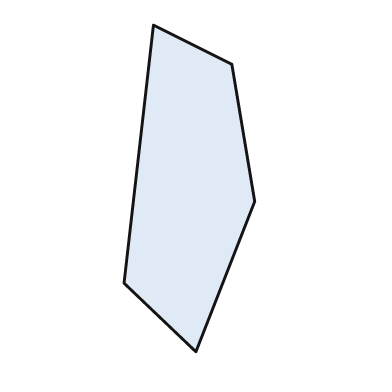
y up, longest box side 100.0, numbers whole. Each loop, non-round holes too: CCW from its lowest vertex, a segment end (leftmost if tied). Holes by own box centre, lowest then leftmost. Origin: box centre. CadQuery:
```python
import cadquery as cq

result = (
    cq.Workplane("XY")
    .moveTo(2.0, -50.0)
    .lineTo(20.0, -4.0)
    .lineTo(13.0, 38.0)
    .lineTo(-11.0, 50.0)
    .lineTo(-20.0, -29.0)
    .close()
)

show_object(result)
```